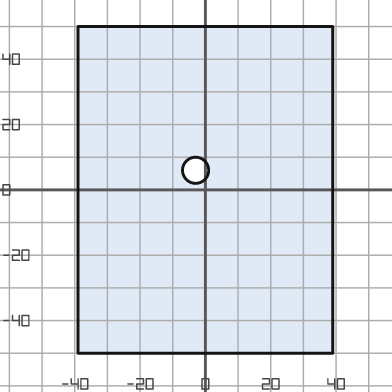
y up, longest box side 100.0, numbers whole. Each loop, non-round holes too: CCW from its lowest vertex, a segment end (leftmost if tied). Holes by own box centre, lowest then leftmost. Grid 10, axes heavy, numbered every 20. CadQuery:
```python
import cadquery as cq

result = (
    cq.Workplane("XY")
    .moveTo(-39.0, -50.0)
    .lineTo(39.0, -50.0)
    .lineTo(39.0, 50.0)
    .lineTo(-39.0, 50.0)
    .close()
    .moveTo(-3.0, 6.0)
    .circle(4.0)
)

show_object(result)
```